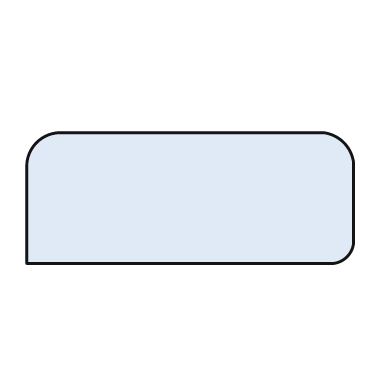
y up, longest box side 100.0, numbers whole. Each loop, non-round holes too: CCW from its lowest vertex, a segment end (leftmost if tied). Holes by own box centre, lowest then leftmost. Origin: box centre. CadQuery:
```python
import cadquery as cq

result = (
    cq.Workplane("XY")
    .moveTo(-50.0, -20.0)
    .lineTo(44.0, -20.0)
    .threePointArc((48.0, -18.0), (50.0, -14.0))
    .lineTo(50.0, 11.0)
    .threePointArc((47.0, 17.0), (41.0, 20.0))
    .lineTo(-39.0, 20.0)
    .threePointArc((-47.0, 17.0), (-50.0, 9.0))
    .close()
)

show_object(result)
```